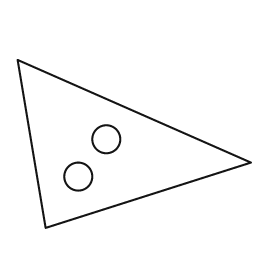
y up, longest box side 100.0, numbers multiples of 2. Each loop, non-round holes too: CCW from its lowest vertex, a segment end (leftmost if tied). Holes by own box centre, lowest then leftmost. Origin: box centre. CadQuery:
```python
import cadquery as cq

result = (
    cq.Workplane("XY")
    .moveTo(-38.0, -36.0)
    .lineTo(50.0, -8.0)
    .lineTo(-50.0, 36.0)
    .close()
    .moveTo(-24.0, -14.0)
    .circle(6.0)
    .moveTo(-12.0, 2.0)
    .circle(6.0)
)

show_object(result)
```